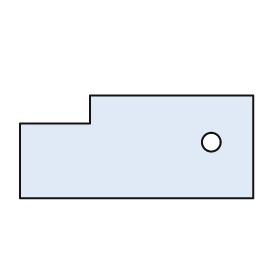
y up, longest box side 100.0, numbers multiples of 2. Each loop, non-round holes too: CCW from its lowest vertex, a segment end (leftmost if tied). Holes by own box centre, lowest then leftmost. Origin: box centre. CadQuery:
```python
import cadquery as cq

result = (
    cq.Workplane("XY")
    .moveTo(-50.0, -22.0)
    .lineTo(50.0, -22.0)
    .lineTo(50.0, 22.0)
    .lineTo(-20.0, 22.0)
    .lineTo(-20.0, 10.0)
    .lineTo(-50.0, 10.0)
    .close()
    .moveTo(32.0, 2.0)
    .circle(4.0)
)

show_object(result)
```